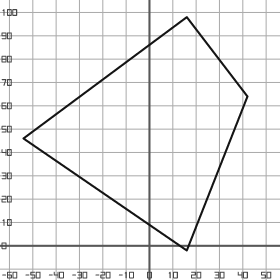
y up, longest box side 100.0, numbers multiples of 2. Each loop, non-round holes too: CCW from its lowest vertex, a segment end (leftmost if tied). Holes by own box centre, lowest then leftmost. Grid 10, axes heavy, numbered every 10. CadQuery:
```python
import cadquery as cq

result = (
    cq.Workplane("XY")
    .moveTo(16.0, -2.0)
    .lineTo(42.0, 64.0)
    .lineTo(16.0, 98.0)
    .lineTo(-54.0, 46.0)
    .close()
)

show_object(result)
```